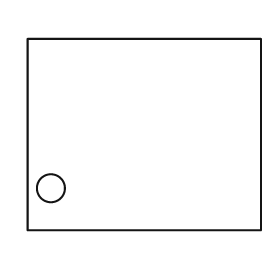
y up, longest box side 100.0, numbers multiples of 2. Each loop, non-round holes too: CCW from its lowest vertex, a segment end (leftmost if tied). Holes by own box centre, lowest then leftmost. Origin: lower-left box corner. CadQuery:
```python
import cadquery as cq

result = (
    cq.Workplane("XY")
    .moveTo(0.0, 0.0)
    .lineTo(100.0, 0.0)
    .lineTo(100.0, 82.0)
    .lineTo(0.0, 82.0)
    .close()
    .moveTo(10.0, 18.0)
    .circle(6.0)
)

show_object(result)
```